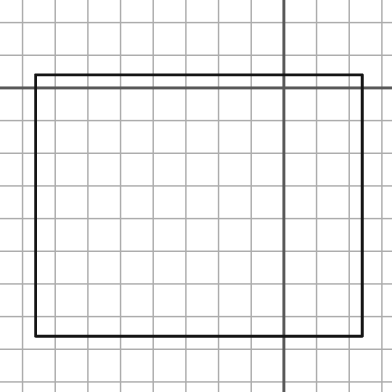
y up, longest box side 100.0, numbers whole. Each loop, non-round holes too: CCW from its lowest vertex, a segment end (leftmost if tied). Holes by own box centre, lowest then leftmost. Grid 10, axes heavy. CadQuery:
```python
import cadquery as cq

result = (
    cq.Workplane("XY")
    .moveTo(-76.0, -76.0)
    .lineTo(24.0, -76.0)
    .lineTo(24.0, 4.0)
    .lineTo(-76.0, 4.0)
    .close()
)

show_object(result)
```